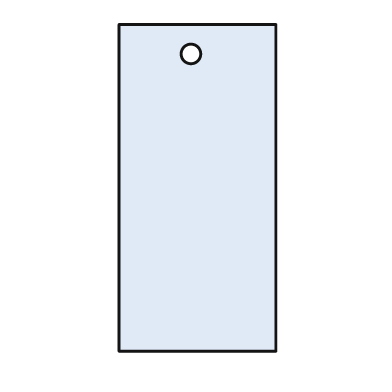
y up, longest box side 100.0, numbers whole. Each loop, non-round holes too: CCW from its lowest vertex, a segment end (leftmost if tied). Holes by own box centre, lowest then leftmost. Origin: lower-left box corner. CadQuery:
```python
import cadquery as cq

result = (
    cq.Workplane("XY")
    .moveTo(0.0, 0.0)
    .lineTo(48.0, 0.0)
    .lineTo(48.0, 100.0)
    .lineTo(0.0, 100.0)
    .close()
    .moveTo(22.0, 91.0)
    .circle(3.0)
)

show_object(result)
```